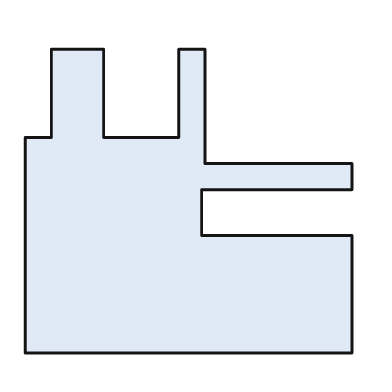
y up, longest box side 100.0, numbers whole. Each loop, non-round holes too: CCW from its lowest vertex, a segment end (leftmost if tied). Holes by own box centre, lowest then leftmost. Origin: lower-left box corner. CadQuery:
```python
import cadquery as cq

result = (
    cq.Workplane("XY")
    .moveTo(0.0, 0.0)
    .lineTo(100.0, 0.0)
    .lineTo(100.0, 36.0)
    .lineTo(54.0, 36.0)
    .lineTo(54.0, 50.0)
    .lineTo(100.0, 50.0)
    .lineTo(100.0, 58.0)
    .lineTo(55.0, 58.0)
    .lineTo(55.0, 93.0)
    .lineTo(47.0, 93.0)
    .lineTo(47.0, 66.0)
    .lineTo(24.0, 66.0)
    .lineTo(24.0, 93.0)
    .lineTo(8.0, 93.0)
    .lineTo(8.0, 66.0)
    .lineTo(0.0, 66.0)
    .close()
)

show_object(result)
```